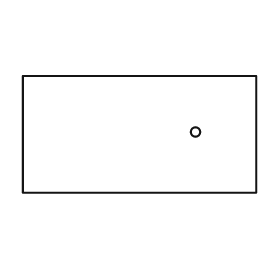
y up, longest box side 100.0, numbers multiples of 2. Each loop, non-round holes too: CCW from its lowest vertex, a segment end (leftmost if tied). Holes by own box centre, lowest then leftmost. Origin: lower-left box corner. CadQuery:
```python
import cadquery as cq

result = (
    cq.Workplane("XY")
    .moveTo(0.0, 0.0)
    .lineTo(100.0, 0.0)
    .lineTo(100.0, 50.0)
    .lineTo(0.0, 50.0)
    .close()
    .moveTo(74.0, 26.0)
    .circle(2.0)
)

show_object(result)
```